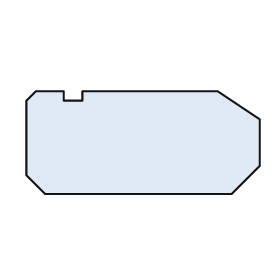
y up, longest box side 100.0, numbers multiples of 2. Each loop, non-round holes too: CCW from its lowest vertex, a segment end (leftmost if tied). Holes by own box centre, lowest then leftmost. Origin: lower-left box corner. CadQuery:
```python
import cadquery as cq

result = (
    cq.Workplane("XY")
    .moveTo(8.0, 0.0)
    .lineTo(88.0, 0.0)
    .lineTo(100.0, 12.0)
    .lineTo(100.0, 32.0)
    .lineTo(82.0, 44.0)
    .lineTo(24.0, 44.0)
    .lineTo(24.0, 40.0)
    .lineTo(16.0, 40.0)
    .lineTo(16.0, 44.0)
    .lineTo(4.0, 44.0)
    .lineTo(0.0, 40.0)
    .lineTo(0.0, 8.0)
    .close()
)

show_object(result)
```